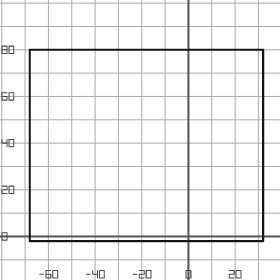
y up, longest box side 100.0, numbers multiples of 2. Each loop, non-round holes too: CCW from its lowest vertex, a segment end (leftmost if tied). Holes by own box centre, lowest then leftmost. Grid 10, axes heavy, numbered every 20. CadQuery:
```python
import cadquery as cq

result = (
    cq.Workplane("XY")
    .moveTo(-68.0, -2.0)
    .lineTo(32.0, -2.0)
    .lineTo(32.0, 80.0)
    .lineTo(-68.0, 80.0)
    .close()
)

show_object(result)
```